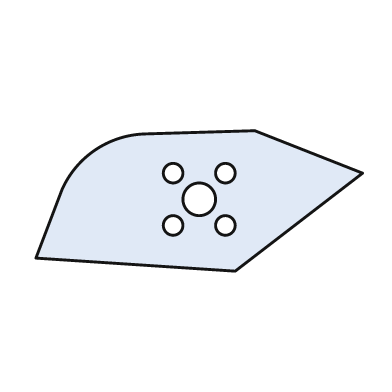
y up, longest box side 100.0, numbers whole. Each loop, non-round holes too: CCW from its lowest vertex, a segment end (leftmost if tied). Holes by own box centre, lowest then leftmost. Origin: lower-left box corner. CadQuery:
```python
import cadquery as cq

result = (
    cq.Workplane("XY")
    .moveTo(61.0, 0.0)
    .lineTo(100.0, 30.0)
    .lineTo(67.0, 43.0)
    .lineTo(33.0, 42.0)
    .threePointArc((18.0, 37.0), (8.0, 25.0))
    .lineTo(0.0, 4.0)
    .close()
    .moveTo(42.0, 14.0)
    .circle(3.0)
    .moveTo(58.0, 14.0)
    .circle(3.0)
    .moveTo(50.0, 22.0)
    .circle(5.0)
    .moveTo(42.0, 30.0)
    .circle(3.0)
    .moveTo(58.0, 30.0)
    .circle(3.0)
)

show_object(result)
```